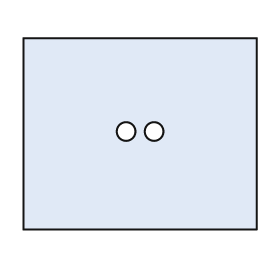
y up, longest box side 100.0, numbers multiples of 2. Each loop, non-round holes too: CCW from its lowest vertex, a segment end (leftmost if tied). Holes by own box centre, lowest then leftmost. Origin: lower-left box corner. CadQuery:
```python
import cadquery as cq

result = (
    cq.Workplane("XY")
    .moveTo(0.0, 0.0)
    .lineTo(100.0, 0.0)
    .lineTo(100.0, 82.0)
    .lineTo(0.0, 82.0)
    .close()
    .moveTo(44.0, 42.0)
    .circle(4.0)
    .moveTo(56.0, 42.0)
    .circle(4.0)
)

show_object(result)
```